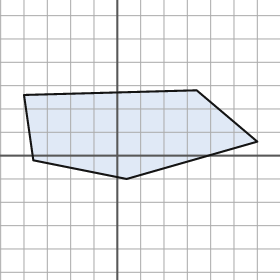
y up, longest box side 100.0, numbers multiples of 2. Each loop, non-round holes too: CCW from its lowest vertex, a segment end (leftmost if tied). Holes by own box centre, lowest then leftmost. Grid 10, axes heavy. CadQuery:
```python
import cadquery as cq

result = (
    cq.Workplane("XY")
    .moveTo(4.0, -10.0)
    .lineTo(60.0, 6.0)
    .lineTo(34.0, 28.0)
    .lineTo(-40.0, 26.0)
    .lineTo(-36.0, -2.0)
    .close()
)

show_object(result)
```